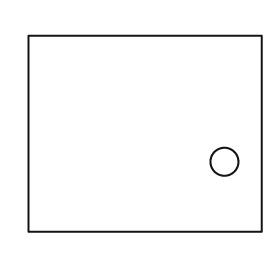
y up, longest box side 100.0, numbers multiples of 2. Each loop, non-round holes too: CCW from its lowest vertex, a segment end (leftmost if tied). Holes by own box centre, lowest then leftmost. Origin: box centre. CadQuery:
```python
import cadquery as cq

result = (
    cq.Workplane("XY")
    .moveTo(-50.0, -42.0)
    .lineTo(50.0, -42.0)
    .lineTo(50.0, 42.0)
    .lineTo(-50.0, 42.0)
    .close()
    .moveTo(34.0, -12.0)
    .circle(6.0)
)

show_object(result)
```